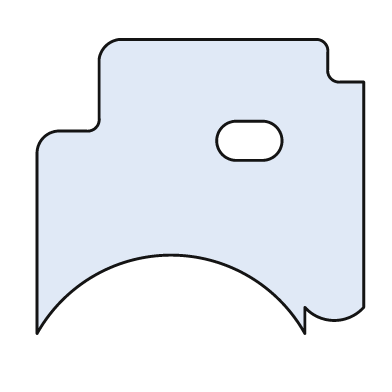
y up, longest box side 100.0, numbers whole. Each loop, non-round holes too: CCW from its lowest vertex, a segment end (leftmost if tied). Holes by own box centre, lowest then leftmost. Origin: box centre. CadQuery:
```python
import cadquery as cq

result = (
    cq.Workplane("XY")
    .moveTo(-50.0, -45.0)
    .threePointArc((-9.0, -21.0), (32.0, -45.0))
    .lineTo(32.0, -37.0)
    .threePointArc((41.0, -41.0), (50.0, -37.0))
    .lineTo(50.0, 32.0)
    .lineTo(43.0, 32.0)
    .threePointArc((40.0, 33.0), (39.0, 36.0))
    .lineTo(39.0, 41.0)
    .threePointArc((38.0, 44.0), (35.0, 45.0))
    .lineTo(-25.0, 45.0)
    .threePointArc((-29.0, 43.0), (-31.0, 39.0))
    .lineTo(-31.0, 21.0)
    .threePointArc((-32.0, 18.0), (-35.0, 17.0))
    .lineTo(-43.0, 17.0)
    .threePointArc((-48.0, 15.0), (-50.0, 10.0))
    .close()
    .moveTo(11.0, 8.0)
    .lineTo(19.0, 8.0)
    .threePointArc((25.0, 14.0), (19.0, 20.0))
    .lineTo(11.0, 20.0)
    .threePointArc((5.0, 14.0), (11.0, 8.0))
    .close()
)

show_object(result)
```